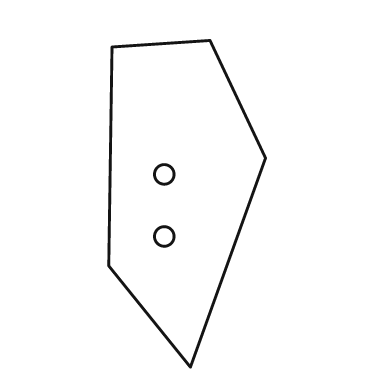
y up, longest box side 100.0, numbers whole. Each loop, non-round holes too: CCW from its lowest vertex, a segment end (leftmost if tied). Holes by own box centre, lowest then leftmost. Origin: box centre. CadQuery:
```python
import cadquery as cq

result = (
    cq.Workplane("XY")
    .moveTo(1.0, -50.0)
    .lineTo(24.0, 14.0)
    .lineTo(7.0, 50.0)
    .lineTo(-23.0, 48.0)
    .lineTo(-24.0, -19.0)
    .close()
    .moveTo(-7.0, -10.0)
    .circle(3.0)
    .moveTo(-7.0, 9.0)
    .circle(3.0)
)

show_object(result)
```